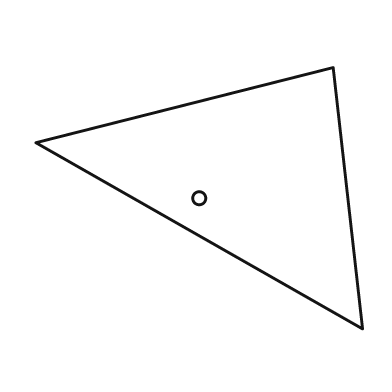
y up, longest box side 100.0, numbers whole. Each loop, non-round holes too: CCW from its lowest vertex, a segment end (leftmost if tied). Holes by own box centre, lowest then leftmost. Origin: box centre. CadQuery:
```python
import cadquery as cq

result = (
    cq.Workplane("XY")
    .moveTo(50.0, -40.0)
    .lineTo(41.0, 40.0)
    .lineTo(-50.0, 17.0)
    .close()
    .moveTo(0.0, 0.0)
    .circle(2.0)
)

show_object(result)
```